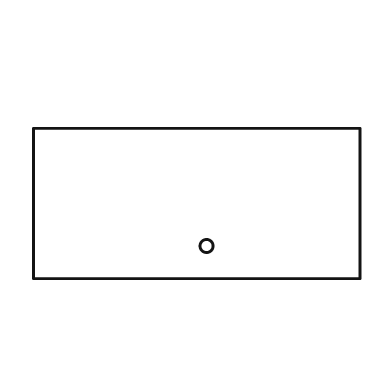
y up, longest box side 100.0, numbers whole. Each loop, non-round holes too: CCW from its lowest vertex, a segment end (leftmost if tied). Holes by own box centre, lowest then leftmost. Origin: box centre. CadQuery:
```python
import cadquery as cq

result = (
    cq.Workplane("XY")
    .moveTo(-50.0, -23.0)
    .lineTo(50.0, -23.0)
    .lineTo(50.0, 23.0)
    .lineTo(-50.0, 23.0)
    .close()
    .moveTo(3.0, -13.0)
    .circle(2.0)
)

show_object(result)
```